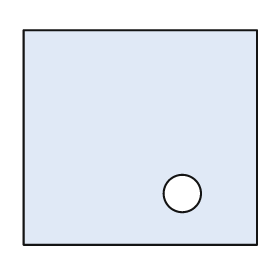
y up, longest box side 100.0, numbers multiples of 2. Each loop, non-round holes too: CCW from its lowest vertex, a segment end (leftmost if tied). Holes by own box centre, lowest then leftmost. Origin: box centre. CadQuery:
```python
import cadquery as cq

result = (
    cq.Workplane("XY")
    .moveTo(-50.0, -46.0)
    .lineTo(50.0, -46.0)
    .lineTo(50.0, 46.0)
    .lineTo(-50.0, 46.0)
    .close()
    .moveTo(18.0, -24.0)
    .circle(8.0)
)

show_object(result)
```